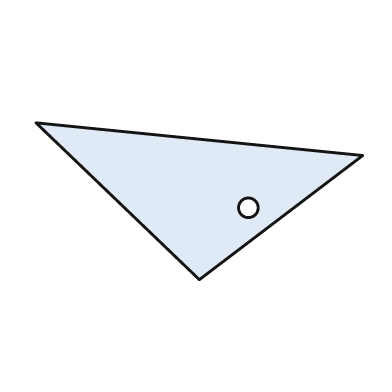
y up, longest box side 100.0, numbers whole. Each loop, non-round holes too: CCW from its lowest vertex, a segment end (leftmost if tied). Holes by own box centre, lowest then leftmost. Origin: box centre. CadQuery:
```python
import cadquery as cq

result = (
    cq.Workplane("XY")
    .moveTo(0.0, -24.0)
    .lineTo(50.0, 14.0)
    .lineTo(-50.0, 24.0)
    .close()
    .moveTo(15.0, -2.0)
    .circle(3.0)
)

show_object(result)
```